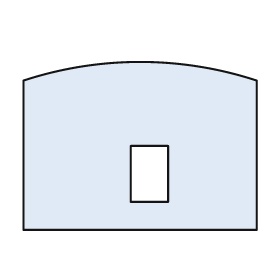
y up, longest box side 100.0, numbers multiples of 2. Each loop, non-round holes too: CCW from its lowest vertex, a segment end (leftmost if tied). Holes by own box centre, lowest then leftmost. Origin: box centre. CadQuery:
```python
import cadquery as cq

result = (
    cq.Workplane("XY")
    .moveTo(-50.0, -36.0)
    .lineTo(50.0, -36.0)
    .lineTo(50.0, 28.0)
    .threePointArc((0.0, 36.0), (-50.0, 28.0))
    .close()
    .moveTo(-4.0, -24.0)
    .lineTo(12.0, -24.0)
    .lineTo(12.0, 0.0)
    .lineTo(-4.0, 0.0)
    .close()
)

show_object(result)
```